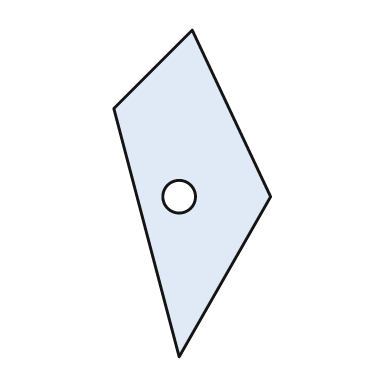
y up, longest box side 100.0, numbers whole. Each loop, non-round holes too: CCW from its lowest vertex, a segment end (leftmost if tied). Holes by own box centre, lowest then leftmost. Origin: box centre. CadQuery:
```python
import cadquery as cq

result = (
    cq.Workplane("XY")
    .moveTo(-4.0, -50.0)
    .lineTo(24.0, -1.0)
    .lineTo(0.0, 50.0)
    .lineTo(-24.0, 26.0)
    .close()
    .moveTo(-4.0, -1.0)
    .circle(5.0)
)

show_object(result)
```